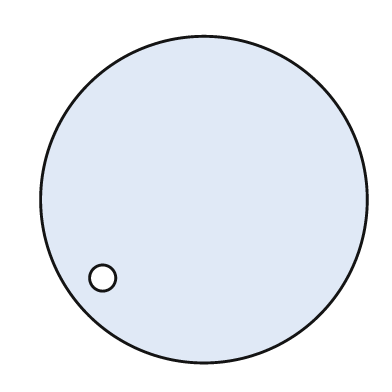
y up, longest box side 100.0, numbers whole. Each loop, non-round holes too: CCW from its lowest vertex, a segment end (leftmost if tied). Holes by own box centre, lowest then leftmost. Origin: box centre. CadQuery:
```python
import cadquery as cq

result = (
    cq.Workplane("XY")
    .moveTo(0.0, 0.0)
    .circle(50.0)
    .moveTo(-31.0, -24.0)
    .circle(4.0)
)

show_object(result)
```